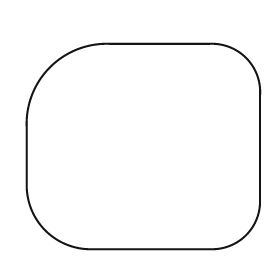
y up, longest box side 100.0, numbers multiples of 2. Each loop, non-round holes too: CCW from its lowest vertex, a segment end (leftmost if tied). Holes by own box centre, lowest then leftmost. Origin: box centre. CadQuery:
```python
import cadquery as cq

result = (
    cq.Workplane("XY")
    .moveTo(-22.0, -44.0)
    .lineTo(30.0, -44.0)
    .threePointArc((44.0, -38.0), (50.0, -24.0))
    .lineTo(50.0, 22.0)
    .threePointArc((44.0, 38.0), (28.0, 44.0))
    .lineTo(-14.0, 44.0)
    .threePointArc((-40.0, 34.0), (-50.0, 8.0))
    .lineTo(-50.0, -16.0)
    .threePointArc((-42.0, -36.0), (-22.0, -44.0))
    .close()
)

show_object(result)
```